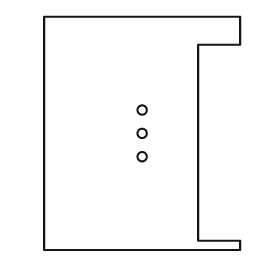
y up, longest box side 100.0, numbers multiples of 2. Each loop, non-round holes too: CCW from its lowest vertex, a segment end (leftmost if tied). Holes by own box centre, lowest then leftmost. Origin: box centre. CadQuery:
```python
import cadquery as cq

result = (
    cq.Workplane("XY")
    .moveTo(-42.0, -50.0)
    .lineTo(42.0, -50.0)
    .lineTo(42.0, -46.0)
    .lineTo(24.0, -46.0)
    .lineTo(24.0, 38.0)
    .lineTo(42.0, 38.0)
    .lineTo(42.0, 50.0)
    .lineTo(-42.0, 50.0)
    .close()
    .moveTo(0.0, -10.0)
    .circle(2.0)
    .moveTo(0.0, 0.0)
    .circle(2.0)
    .moveTo(0.0, 10.0)
    .circle(2.0)
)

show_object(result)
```